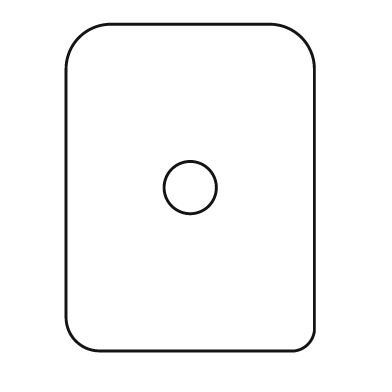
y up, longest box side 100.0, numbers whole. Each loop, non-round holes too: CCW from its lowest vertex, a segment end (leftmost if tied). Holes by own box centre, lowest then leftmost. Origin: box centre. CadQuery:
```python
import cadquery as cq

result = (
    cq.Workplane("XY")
    .moveTo(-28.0, -50.0)
    .lineTo(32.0, -50.0)
    .threePointArc((36.0, -48.0), (38.0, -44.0))
    .lineTo(38.0, 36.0)
    .threePointArc((34.0, 46.0), (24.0, 50.0))
    .lineTo(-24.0, 50.0)
    .threePointArc((-34.0, 46.0), (-38.0, 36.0))
    .lineTo(-38.0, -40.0)
    .threePointArc((-35.0, -47.0), (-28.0, -50.0))
    .close()
    .moveTo(0.0, 0.0)
    .circle(8.0)
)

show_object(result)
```